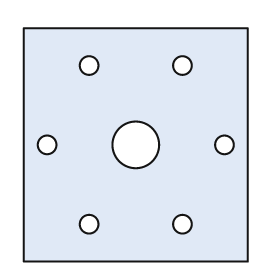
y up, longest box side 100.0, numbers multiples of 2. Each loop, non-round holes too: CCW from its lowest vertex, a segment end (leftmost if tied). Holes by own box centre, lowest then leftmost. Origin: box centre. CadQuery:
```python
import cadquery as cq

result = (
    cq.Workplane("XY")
    .moveTo(-48.0, -50.0)
    .lineTo(48.0, -50.0)
    .lineTo(48.0, 50.0)
    .lineTo(-48.0, 50.0)
    .close()
    .moveTo(-20.0, -34.0)
    .circle(4.0)
    .moveTo(20.0, -34.0)
    .circle(4.0)
    .moveTo(-38.0, 0.0)
    .circle(4.0)
    .moveTo(0.0, 0.0)
    .circle(10.0)
    .moveTo(38.0, 0.0)
    .circle(4.0)
    .moveTo(-20.0, 34.0)
    .circle(4.0)
    .moveTo(20.0, 34.0)
    .circle(4.0)
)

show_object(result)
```